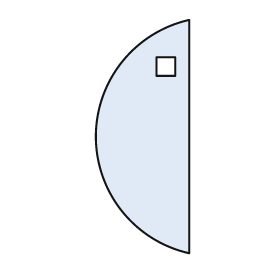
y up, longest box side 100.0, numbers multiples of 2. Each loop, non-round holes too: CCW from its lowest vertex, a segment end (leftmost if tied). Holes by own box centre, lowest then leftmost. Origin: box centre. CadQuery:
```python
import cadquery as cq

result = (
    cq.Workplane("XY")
    .moveTo(20.0, -50.0)
    .lineTo(20.0, 50.0)
    .threePointArc((-20.0, 0.0), (20.0, -50.0))
    .close()
    .moveTo(6.0, 26.0)
    .lineTo(14.0, 26.0)
    .lineTo(14.0, 34.0)
    .lineTo(6.0, 34.0)
    .close()
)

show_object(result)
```